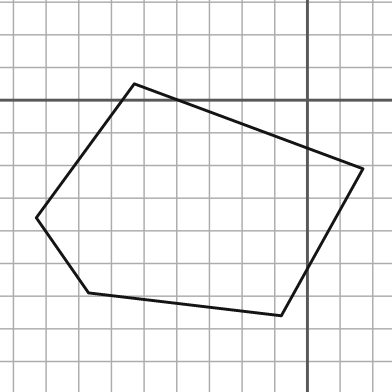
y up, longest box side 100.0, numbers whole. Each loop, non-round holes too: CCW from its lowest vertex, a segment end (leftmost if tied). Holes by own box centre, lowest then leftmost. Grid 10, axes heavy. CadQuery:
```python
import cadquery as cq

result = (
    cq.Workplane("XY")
    .moveTo(-8.0, -66.0)
    .lineTo(17.0, -21.0)
    .lineTo(-53.0, 5.0)
    .lineTo(-83.0, -36.0)
    .lineTo(-67.0, -59.0)
    .close()
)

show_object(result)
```